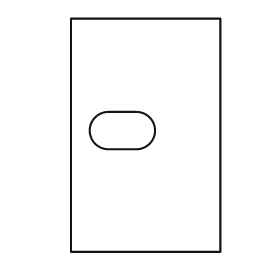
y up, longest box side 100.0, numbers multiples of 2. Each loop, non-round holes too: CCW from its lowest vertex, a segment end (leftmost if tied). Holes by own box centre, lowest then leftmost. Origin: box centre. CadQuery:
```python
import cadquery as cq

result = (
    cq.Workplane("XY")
    .moveTo(-32.0, -50.0)
    .lineTo(32.0, -50.0)
    .lineTo(32.0, 50.0)
    .lineTo(-32.0, 50.0)
    .close()
    .moveTo(-16.0, -6.0)
    .lineTo(-4.0, -6.0)
    .threePointArc((4.0, 2.0), (-4.0, 10.0))
    .lineTo(-16.0, 10.0)
    .threePointArc((-24.0, 2.0), (-16.0, -6.0))
    .close()
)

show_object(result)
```